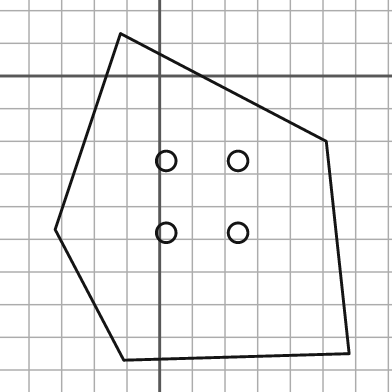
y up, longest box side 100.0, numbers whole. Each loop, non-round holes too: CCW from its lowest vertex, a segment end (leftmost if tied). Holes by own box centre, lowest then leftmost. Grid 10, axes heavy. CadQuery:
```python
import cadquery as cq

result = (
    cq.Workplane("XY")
    .moveTo(-11.0, -87.0)
    .lineTo(58.0, -85.0)
    .lineTo(51.0, -20.0)
    .lineTo(-12.0, 13.0)
    .lineTo(-32.0, -47.0)
    .close()
    .moveTo(2.0, -48.0)
    .circle(3.0)
    .moveTo(24.0, -48.0)
    .circle(3.0)
    .moveTo(2.0, -26.0)
    .circle(3.0)
    .moveTo(24.0, -26.0)
    .circle(3.0)
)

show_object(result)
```